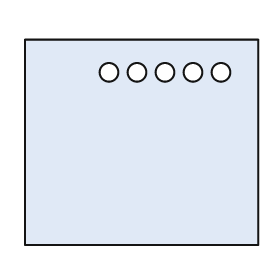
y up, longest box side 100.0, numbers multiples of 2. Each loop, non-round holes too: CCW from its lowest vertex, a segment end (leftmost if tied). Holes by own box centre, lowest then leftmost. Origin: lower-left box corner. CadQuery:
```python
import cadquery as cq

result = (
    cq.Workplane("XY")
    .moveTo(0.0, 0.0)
    .lineTo(100.0, 0.0)
    .lineTo(100.0, 88.0)
    .lineTo(0.0, 88.0)
    .close()
    .moveTo(36.0, 74.0)
    .circle(4.0)
    .moveTo(48.0, 74.0)
    .circle(4.0)
    .moveTo(60.0, 74.0)
    .circle(4.0)
    .moveTo(72.0, 74.0)
    .circle(4.0)
    .moveTo(84.0, 74.0)
    .circle(4.0)
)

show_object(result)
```